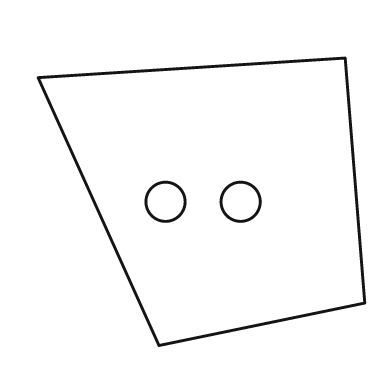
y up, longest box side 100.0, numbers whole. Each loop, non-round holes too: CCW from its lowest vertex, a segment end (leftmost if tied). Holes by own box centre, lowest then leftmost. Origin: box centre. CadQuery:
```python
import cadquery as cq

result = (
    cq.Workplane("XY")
    .moveTo(-13.0, -44.0)
    .lineTo(50.0, -31.0)
    .lineTo(44.0, 44.0)
    .lineTo(-50.0, 38.0)
    .close()
    .moveTo(-11.0, 0.0)
    .circle(6.0)
    .moveTo(12.0, 0.0)
    .circle(6.0)
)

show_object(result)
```